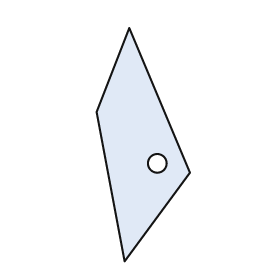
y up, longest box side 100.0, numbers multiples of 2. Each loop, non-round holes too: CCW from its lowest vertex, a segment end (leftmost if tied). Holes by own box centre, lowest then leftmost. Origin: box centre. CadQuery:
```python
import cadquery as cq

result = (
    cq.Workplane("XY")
    .moveTo(-8.0, -50.0)
    .lineTo(20.0, -12.0)
    .lineTo(-6.0, 50.0)
    .lineTo(-20.0, 14.0)
    .close()
    .moveTo(6.0, -8.0)
    .circle(4.0)
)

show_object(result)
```